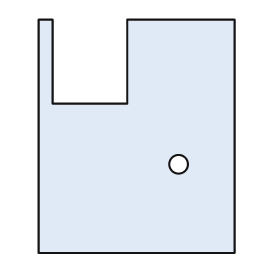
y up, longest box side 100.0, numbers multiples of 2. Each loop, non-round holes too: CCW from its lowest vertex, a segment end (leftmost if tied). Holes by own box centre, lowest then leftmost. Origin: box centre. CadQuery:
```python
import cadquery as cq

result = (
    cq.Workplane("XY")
    .moveTo(-42.0, -50.0)
    .lineTo(42.0, -50.0)
    .lineTo(42.0, 50.0)
    .lineTo(-4.0, 50.0)
    .lineTo(-4.0, 14.0)
    .lineTo(-36.0, 14.0)
    .lineTo(-36.0, 50.0)
    .lineTo(-42.0, 50.0)
    .close()
    .moveTo(18.0, -12.0)
    .circle(4.0)
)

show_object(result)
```